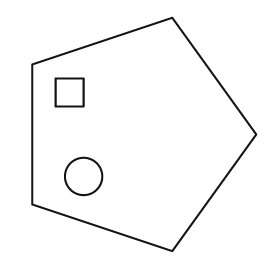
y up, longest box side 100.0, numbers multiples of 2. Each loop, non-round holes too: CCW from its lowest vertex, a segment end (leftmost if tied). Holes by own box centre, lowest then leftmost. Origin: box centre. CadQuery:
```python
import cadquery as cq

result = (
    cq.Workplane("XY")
    .moveTo(12.0, -50.0)
    .lineTo(48.0, 0.0)
    .lineTo(12.0, 50.0)
    .lineTo(-48.0, 30.0)
    .lineTo(-48.0, -30.0)
    .close()
    .moveTo(-26.0, -18.0)
    .circle(8.0)
    .moveTo(-38.0, 12.0)
    .lineTo(-26.0, 12.0)
    .lineTo(-26.0, 24.0)
    .lineTo(-38.0, 24.0)
    .close()
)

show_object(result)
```